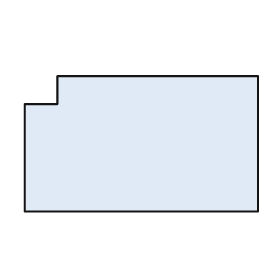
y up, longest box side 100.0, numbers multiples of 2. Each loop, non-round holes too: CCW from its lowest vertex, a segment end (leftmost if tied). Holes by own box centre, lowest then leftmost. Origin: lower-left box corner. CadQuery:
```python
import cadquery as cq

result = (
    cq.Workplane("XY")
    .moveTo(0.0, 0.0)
    .lineTo(100.0, 0.0)
    .lineTo(100.0, 58.0)
    .lineTo(14.0, 58.0)
    .lineTo(14.0, 46.0)
    .lineTo(0.0, 46.0)
    .close()
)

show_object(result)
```